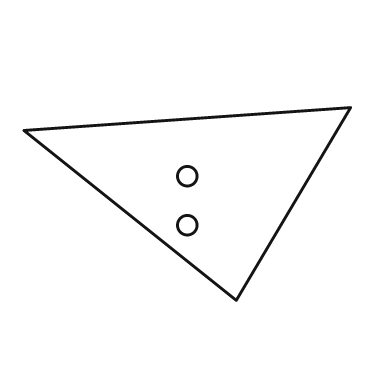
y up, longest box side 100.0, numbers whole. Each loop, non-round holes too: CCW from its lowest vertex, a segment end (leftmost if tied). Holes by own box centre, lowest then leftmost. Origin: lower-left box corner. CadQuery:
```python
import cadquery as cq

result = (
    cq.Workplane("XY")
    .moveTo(65.0, 0.0)
    .lineTo(100.0, 59.0)
    .lineTo(0.0, 52.0)
    .close()
    .moveTo(50.0, 23.0)
    .circle(3.0)
    .moveTo(50.0, 38.0)
    .circle(3.0)
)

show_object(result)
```